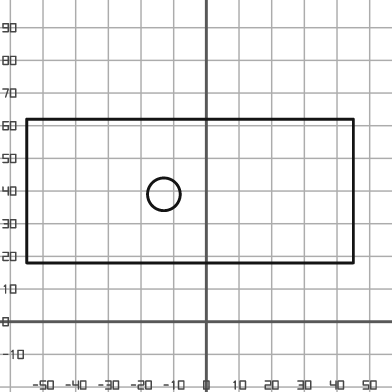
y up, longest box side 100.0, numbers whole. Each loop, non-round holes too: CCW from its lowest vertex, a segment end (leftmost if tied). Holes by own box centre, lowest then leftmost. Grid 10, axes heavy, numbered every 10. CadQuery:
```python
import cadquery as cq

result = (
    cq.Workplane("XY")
    .moveTo(-55.0, 18.0)
    .lineTo(45.0, 18.0)
    .lineTo(45.0, 62.0)
    .lineTo(-55.0, 62.0)
    .close()
    .moveTo(-13.0, 39.0)
    .circle(5.0)
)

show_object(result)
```